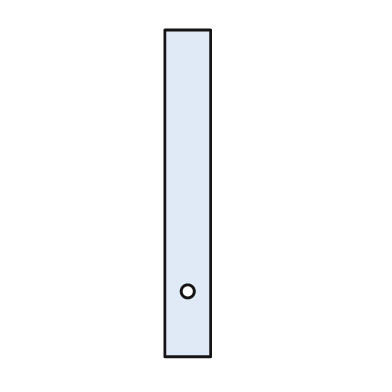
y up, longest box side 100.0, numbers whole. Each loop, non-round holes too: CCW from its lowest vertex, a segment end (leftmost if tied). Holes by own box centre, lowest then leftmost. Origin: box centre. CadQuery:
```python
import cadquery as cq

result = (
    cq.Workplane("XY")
    .moveTo(-7.0, -50.0)
    .lineTo(7.0, -50.0)
    .lineTo(7.0, 50.0)
    .lineTo(-7.0, 50.0)
    .close()
    .moveTo(0.0, -30.0)
    .circle(2.0)
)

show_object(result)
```